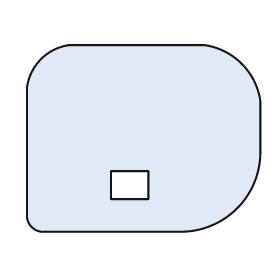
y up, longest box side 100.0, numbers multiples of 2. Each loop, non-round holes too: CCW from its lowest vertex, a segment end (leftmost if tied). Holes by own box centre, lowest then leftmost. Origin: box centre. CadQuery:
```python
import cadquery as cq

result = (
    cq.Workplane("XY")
    .moveTo(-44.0, -40.0)
    .lineTo(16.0, -40.0)
    .threePointArc((40.0, -30.0), (50.0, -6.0))
    .lineTo(50.0, 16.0)
    .threePointArc((42.0, 32.0), (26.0, 40.0))
    .lineTo(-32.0, 40.0)
    .threePointArc((-44.0, 34.0), (-50.0, 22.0))
    .lineTo(-50.0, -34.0)
    .threePointArc((-48.0, -38.0), (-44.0, -40.0))
    .close()
    .moveTo(-14.0, -26.0)
    .lineTo(2.0, -26.0)
    .lineTo(2.0, -14.0)
    .lineTo(-14.0, -14.0)
    .close()
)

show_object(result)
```